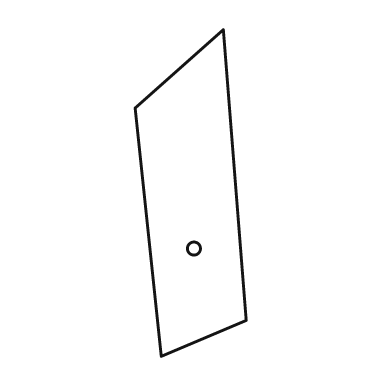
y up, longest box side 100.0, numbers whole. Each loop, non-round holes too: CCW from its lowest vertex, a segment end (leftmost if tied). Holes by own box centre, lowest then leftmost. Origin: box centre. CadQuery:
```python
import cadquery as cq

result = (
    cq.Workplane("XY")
    .moveTo(-9.0, -50.0)
    .lineTo(17.0, -39.0)
    .lineTo(10.0, 50.0)
    .lineTo(-17.0, 26.0)
    .close()
    .moveTo(1.0, -17.0)
    .circle(2.0)
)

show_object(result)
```